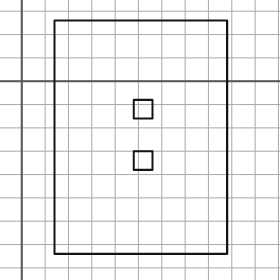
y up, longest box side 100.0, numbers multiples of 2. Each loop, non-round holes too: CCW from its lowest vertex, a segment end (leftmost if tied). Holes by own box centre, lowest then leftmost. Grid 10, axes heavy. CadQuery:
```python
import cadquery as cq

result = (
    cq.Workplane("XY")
    .moveTo(14.0, -74.0)
    .lineTo(88.0, -74.0)
    .lineTo(88.0, 26.0)
    .lineTo(14.0, 26.0)
    .close()
    .moveTo(48.0, -38.0)
    .lineTo(56.0, -38.0)
    .lineTo(56.0, -30.0)
    .lineTo(48.0, -30.0)
    .close()
    .moveTo(48.0, -16.0)
    .lineTo(56.0, -16.0)
    .lineTo(56.0, -8.0)
    .lineTo(48.0, -8.0)
    .close()
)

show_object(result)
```